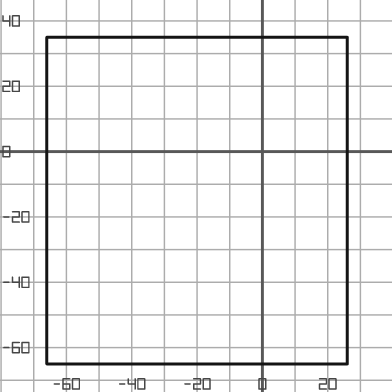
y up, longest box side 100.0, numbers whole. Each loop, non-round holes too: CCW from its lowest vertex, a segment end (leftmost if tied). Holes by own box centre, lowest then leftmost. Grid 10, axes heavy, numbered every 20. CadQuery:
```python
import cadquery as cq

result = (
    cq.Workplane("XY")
    .moveTo(-66.0, -65.0)
    .lineTo(26.0, -65.0)
    .lineTo(26.0, 35.0)
    .lineTo(-66.0, 35.0)
    .close()
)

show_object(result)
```